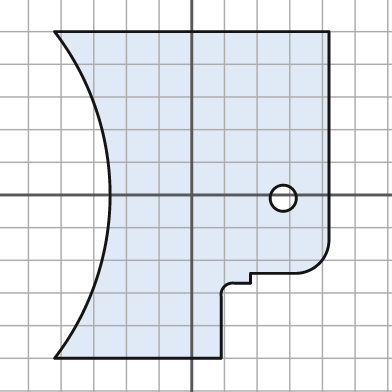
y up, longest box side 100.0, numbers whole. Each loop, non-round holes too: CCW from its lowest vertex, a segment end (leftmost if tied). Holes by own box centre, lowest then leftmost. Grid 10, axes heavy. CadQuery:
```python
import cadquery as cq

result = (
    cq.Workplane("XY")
    .moveTo(-42.0, -50.0)
    .lineTo(9.0, -50.0)
    .lineTo(9.0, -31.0)
    .threePointArc((10.0, -28.0), (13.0, -27.0))
    .lineTo(18.0, -27.0)
    .lineTo(18.0, -24.0)
    .lineTo(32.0, -24.0)
    .threePointArc((39.0, -21.0), (42.0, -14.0))
    .lineTo(42.0, 50.0)
    .lineTo(-42.0, 50.0)
    .threePointArc((-25.0, 0.0), (-42.0, -50.0))
    .close()
    .moveTo(28.0, -1.0)
    .circle(4.0)
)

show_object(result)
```